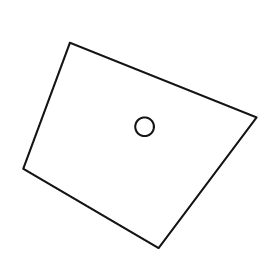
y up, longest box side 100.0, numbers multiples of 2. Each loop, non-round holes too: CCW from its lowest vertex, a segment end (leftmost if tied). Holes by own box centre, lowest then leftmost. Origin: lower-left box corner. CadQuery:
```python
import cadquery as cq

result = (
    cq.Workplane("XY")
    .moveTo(58.0, 0.0)
    .lineTo(100.0, 56.0)
    .lineTo(20.0, 88.0)
    .lineTo(0.0, 34.0)
    .close()
    .moveTo(52.0, 52.0)
    .circle(4.0)
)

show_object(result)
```